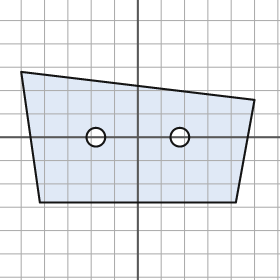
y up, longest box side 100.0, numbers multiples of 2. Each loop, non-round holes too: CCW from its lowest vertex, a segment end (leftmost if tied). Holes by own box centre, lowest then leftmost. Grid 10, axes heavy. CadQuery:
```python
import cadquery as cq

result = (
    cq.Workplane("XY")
    .moveTo(-42.0, -28.0)
    .lineTo(42.0, -28.0)
    .lineTo(50.0, 16.0)
    .lineTo(-50.0, 28.0)
    .close()
    .moveTo(-18.0, 0.0)
    .circle(4.0)
    .moveTo(18.0, 0.0)
    .circle(4.0)
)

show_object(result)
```